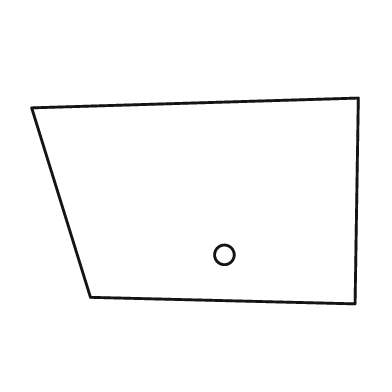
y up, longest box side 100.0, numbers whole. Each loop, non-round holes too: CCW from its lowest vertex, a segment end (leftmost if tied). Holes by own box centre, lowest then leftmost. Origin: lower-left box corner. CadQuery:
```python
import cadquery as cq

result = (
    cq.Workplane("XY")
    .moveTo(99.0, 0.0)
    .lineTo(100.0, 63.0)
    .lineTo(0.0, 60.0)
    .lineTo(18.0, 2.0)
    .close()
    .moveTo(59.0, 15.0)
    .circle(3.0)
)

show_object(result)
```